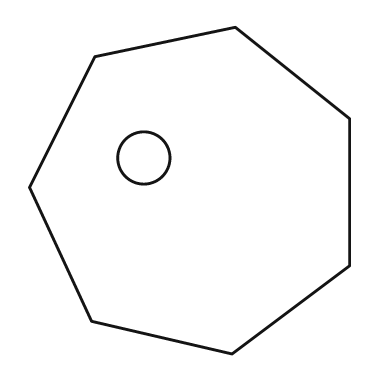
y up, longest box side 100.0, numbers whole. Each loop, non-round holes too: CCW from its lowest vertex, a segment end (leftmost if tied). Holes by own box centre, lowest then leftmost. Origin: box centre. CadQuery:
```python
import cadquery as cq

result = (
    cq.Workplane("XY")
    .moveTo(13.0, -50.0)
    .lineTo(49.0, -23.0)
    .lineTo(49.0, 22.0)
    .lineTo(14.0, 50.0)
    .lineTo(-29.0, 41.0)
    .lineTo(-49.0, 1.0)
    .lineTo(-30.0, -40.0)
    .close()
    .moveTo(-14.0, 10.0)
    .circle(8.0)
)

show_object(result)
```